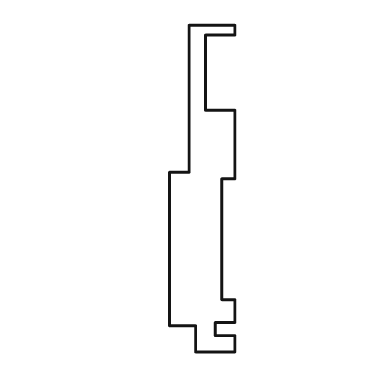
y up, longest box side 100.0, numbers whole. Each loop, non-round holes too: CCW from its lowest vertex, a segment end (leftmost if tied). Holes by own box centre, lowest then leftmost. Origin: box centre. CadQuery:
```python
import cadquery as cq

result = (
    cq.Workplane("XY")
    .moveTo(-2.0, -50.0)
    .lineTo(10.0, -50.0)
    .lineTo(10.0, -45.0)
    .lineTo(4.0, -45.0)
    .lineTo(4.0, -41.0)
    .lineTo(10.0, -41.0)
    .lineTo(10.0, -34.0)
    .lineTo(6.0, -34.0)
    .lineTo(6.0, 3.0)
    .lineTo(10.0, 3.0)
    .lineTo(10.0, 24.0)
    .lineTo(1.0, 24.0)
    .lineTo(1.0, 47.0)
    .lineTo(10.0, 47.0)
    .lineTo(10.0, 50.0)
    .lineTo(-4.0, 50.0)
    .lineTo(-4.0, 5.0)
    .lineTo(-10.0, 5.0)
    .lineTo(-10.0, -42.0)
    .lineTo(-2.0, -42.0)
    .close()
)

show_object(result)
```